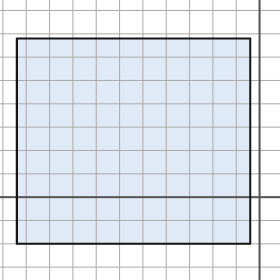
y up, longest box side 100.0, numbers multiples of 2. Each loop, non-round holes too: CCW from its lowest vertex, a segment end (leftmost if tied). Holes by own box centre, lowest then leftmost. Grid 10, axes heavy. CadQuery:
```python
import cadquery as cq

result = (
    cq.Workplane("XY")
    .moveTo(-104.0, -20.0)
    .lineTo(-4.0, -20.0)
    .lineTo(-4.0, 68.0)
    .lineTo(-104.0, 68.0)
    .close()
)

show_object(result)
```